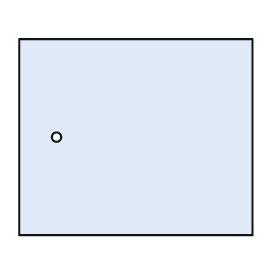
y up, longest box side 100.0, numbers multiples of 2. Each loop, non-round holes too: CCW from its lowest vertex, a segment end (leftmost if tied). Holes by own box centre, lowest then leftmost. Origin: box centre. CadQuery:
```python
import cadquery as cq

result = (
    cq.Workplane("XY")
    .moveTo(-50.0, -42.0)
    .lineTo(50.0, -42.0)
    .lineTo(50.0, 42.0)
    .lineTo(-50.0, 42.0)
    .close()
    .moveTo(-34.0, 0.0)
    .circle(2.0)
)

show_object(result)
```